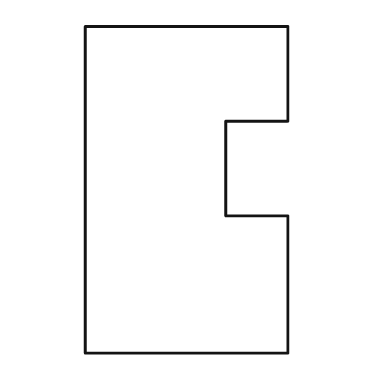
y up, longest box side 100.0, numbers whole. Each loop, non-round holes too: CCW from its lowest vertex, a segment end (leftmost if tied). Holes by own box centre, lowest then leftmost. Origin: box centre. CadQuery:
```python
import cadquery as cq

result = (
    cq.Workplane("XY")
    .moveTo(-31.0, -50.0)
    .lineTo(31.0, -50.0)
    .lineTo(31.0, -8.0)
    .lineTo(12.0, -8.0)
    .lineTo(12.0, 21.0)
    .lineTo(31.0, 21.0)
    .lineTo(31.0, 50.0)
    .lineTo(-31.0, 50.0)
    .close()
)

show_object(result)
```